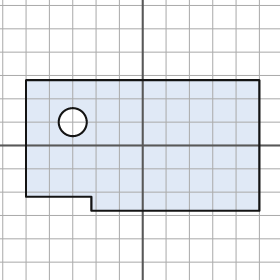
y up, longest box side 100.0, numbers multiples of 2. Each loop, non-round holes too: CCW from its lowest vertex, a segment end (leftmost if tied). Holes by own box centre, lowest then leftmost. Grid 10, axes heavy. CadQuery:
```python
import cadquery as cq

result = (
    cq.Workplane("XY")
    .moveTo(-22.0, -28.0)
    .lineTo(50.0, -28.0)
    .lineTo(50.0, 28.0)
    .lineTo(-50.0, 28.0)
    .lineTo(-50.0, -22.0)
    .lineTo(-22.0, -22.0)
    .close()
    .moveTo(-30.0, 10.0)
    .circle(6.0)
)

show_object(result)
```